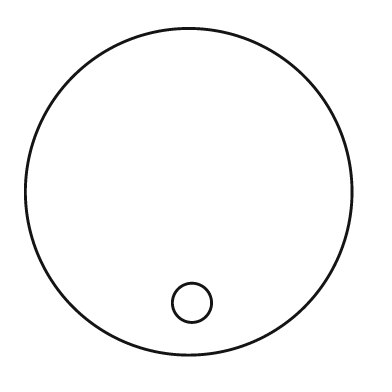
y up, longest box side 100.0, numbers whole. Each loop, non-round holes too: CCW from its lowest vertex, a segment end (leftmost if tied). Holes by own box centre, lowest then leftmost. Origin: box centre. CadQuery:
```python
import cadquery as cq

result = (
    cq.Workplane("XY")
    .moveTo(0.0, 0.0)
    .circle(50.0)
    .moveTo(1.0, -34.0)
    .circle(6.0)
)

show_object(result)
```